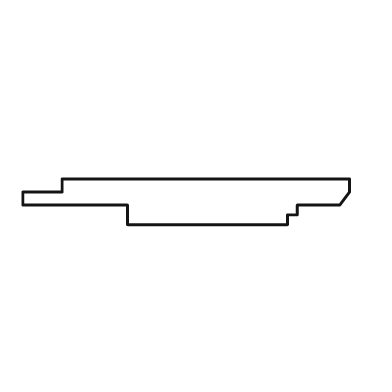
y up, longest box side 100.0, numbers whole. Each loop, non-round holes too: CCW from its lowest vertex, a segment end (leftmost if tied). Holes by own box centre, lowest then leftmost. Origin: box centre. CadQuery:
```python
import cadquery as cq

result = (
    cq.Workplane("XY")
    .moveTo(-18.0, -7.0)
    .lineTo(31.0, -7.0)
    .lineTo(31.0, -4.0)
    .lineTo(34.0, -4.0)
    .lineTo(34.0, -1.0)
    .lineTo(47.0, -1.0)
    .lineTo(50.0, 3.0)
    .lineTo(50.0, 7.0)
    .lineTo(-38.0, 7.0)
    .lineTo(-38.0, 3.0)
    .lineTo(-50.0, 3.0)
    .lineTo(-50.0, -1.0)
    .lineTo(-18.0, -1.0)
    .close()
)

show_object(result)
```